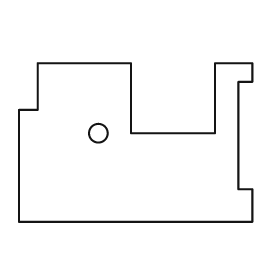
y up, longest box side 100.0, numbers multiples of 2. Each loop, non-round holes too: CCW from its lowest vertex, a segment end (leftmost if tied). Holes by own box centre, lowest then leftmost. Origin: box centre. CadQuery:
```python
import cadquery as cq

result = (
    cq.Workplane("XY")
    .moveTo(-50.0, -34.0)
    .lineTo(50.0, -34.0)
    .lineTo(50.0, -20.0)
    .lineTo(44.0, -20.0)
    .lineTo(44.0, 26.0)
    .lineTo(50.0, 26.0)
    .lineTo(50.0, 34.0)
    .lineTo(34.0, 34.0)
    .lineTo(34.0, 4.0)
    .lineTo(-2.0, 4.0)
    .lineTo(-2.0, 34.0)
    .lineTo(-42.0, 34.0)
    .lineTo(-42.0, 14.0)
    .lineTo(-50.0, 14.0)
    .close()
    .moveTo(-16.0, 4.0)
    .circle(4.0)
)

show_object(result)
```